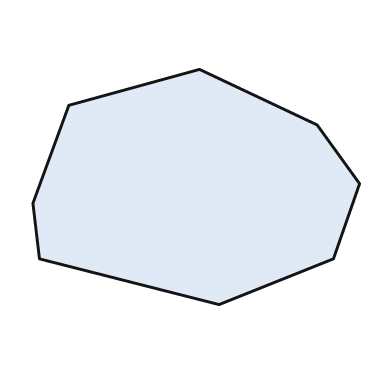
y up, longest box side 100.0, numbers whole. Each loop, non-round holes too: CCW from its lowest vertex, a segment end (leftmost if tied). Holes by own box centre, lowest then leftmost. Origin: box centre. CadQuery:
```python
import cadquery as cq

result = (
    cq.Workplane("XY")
    .moveTo(7.0, -36.0)
    .lineTo(42.0, -22.0)
    .lineTo(50.0, 1.0)
    .lineTo(37.0, 19.0)
    .lineTo(1.0, 36.0)
    .lineTo(-39.0, 25.0)
    .lineTo(-50.0, -5.0)
    .lineTo(-48.0, -22.0)
    .close()
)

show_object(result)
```